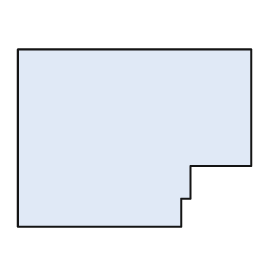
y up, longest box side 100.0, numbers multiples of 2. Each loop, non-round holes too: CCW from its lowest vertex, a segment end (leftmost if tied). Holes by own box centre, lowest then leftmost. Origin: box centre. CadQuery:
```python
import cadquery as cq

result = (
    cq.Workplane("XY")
    .moveTo(-50.0, -38.0)
    .lineTo(20.0, -38.0)
    .lineTo(20.0, -26.0)
    .lineTo(24.0, -26.0)
    .lineTo(24.0, -12.0)
    .lineTo(50.0, -12.0)
    .lineTo(50.0, 38.0)
    .lineTo(-50.0, 38.0)
    .close()
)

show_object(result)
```